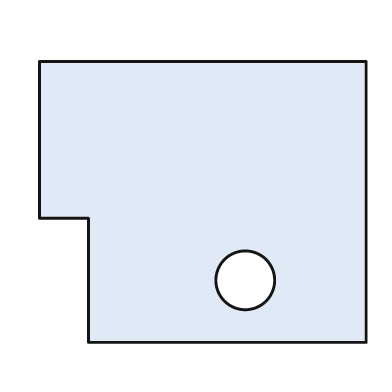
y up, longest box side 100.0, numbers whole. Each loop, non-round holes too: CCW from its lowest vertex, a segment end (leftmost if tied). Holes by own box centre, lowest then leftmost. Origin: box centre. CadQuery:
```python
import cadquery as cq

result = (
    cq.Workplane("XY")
    .moveTo(-35.0, -43.0)
    .lineTo(50.0, -43.0)
    .lineTo(50.0, 43.0)
    .lineTo(-50.0, 43.0)
    .lineTo(-50.0, -5.0)
    .lineTo(-35.0, -5.0)
    .close()
    .moveTo(13.0, -24.0)
    .circle(9.0)
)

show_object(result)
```